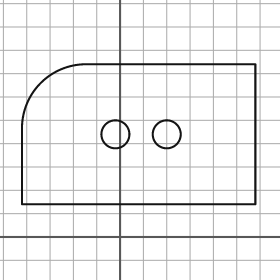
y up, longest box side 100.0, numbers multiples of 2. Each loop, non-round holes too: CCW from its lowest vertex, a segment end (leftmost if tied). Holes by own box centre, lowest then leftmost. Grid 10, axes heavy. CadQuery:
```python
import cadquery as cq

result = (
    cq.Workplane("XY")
    .moveTo(-42.0, 14.0)
    .lineTo(58.0, 14.0)
    .lineTo(58.0, 74.0)
    .lineTo(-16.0, 74.0)
    .threePointArc((-34.0, 66.0), (-42.0, 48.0))
    .close()
    .moveTo(-2.0, 44.0)
    .circle(6.0)
    .moveTo(20.0, 44.0)
    .circle(6.0)
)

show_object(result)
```